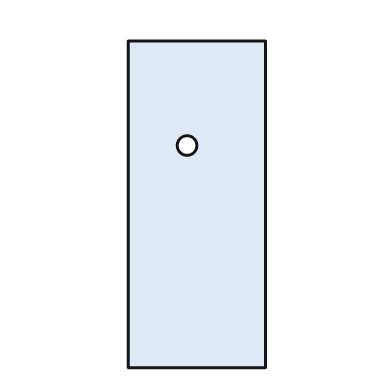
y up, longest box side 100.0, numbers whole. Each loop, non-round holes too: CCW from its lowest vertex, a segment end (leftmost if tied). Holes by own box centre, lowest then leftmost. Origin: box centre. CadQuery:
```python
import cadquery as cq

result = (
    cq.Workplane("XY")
    .moveTo(-21.0, -50.0)
    .lineTo(21.0, -50.0)
    .lineTo(21.0, 50.0)
    .lineTo(-21.0, 50.0)
    .close()
    .moveTo(-3.0, 18.0)
    .circle(3.0)
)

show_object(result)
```